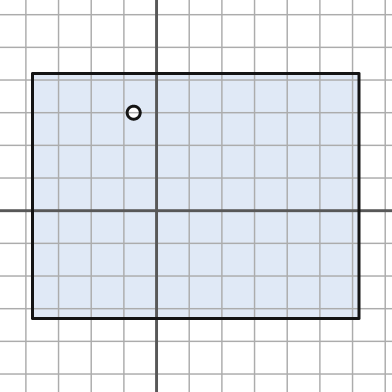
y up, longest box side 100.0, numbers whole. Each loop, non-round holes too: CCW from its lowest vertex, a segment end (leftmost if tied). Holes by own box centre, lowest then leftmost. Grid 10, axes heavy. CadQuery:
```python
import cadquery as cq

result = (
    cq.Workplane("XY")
    .moveTo(-38.0, -33.0)
    .lineTo(62.0, -33.0)
    .lineTo(62.0, 42.0)
    .lineTo(-38.0, 42.0)
    .close()
    .moveTo(-7.0, 30.0)
    .circle(2.0)
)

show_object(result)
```